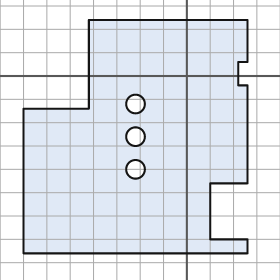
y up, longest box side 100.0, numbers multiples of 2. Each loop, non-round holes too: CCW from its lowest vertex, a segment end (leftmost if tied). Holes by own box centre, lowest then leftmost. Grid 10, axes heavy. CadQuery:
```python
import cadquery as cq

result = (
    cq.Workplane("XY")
    .moveTo(-70.0, -76.0)
    .lineTo(26.0, -76.0)
    .lineTo(26.0, -70.0)
    .lineTo(10.0, -70.0)
    .lineTo(10.0, -46.0)
    .lineTo(26.0, -46.0)
    .lineTo(26.0, -4.0)
    .lineTo(22.0, -4.0)
    .lineTo(22.0, 6.0)
    .lineTo(26.0, 6.0)
    .lineTo(26.0, 24.0)
    .lineTo(-42.0, 24.0)
    .lineTo(-42.0, -14.0)
    .lineTo(-70.0, -14.0)
    .close()
    .moveTo(-22.0, -40.0)
    .circle(4.0)
    .moveTo(-22.0, -26.0)
    .circle(4.0)
    .moveTo(-22.0, -12.0)
    .circle(4.0)
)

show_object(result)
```